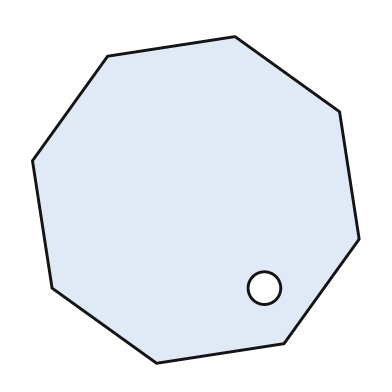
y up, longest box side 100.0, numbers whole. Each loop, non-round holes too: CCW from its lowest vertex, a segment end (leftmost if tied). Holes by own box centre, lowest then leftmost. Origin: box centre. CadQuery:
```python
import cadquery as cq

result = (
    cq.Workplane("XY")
    .moveTo(-12.0, -50.0)
    .lineTo(27.0, -44.0)
    .lineTo(50.0, -12.0)
    .lineTo(44.0, 27.0)
    .lineTo(12.0, 50.0)
    .lineTo(-27.0, 44.0)
    .lineTo(-50.0, 12.0)
    .lineTo(-44.0, -27.0)
    .close()
    .moveTo(21.0, -27.0)
    .circle(5.0)
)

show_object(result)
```